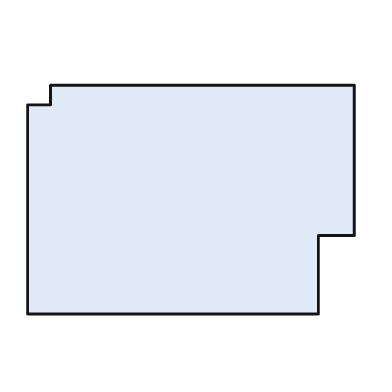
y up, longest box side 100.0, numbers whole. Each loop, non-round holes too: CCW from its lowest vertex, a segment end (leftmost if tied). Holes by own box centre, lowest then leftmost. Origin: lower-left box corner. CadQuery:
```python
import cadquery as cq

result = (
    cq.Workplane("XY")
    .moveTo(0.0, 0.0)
    .lineTo(89.0, 0.0)
    .lineTo(89.0, 24.0)
    .lineTo(100.0, 24.0)
    .lineTo(100.0, 70.0)
    .lineTo(7.0, 70.0)
    .lineTo(7.0, 64.0)
    .lineTo(0.0, 64.0)
    .close()
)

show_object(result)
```